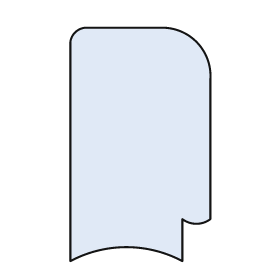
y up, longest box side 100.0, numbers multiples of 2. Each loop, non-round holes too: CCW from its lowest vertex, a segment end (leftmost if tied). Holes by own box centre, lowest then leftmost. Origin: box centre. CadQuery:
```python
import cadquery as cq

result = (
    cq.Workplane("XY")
    .moveTo(-30.0, -50.0)
    .threePointArc((-6.0, -44.0), (18.0, -50.0))
    .lineTo(18.0, -32.0)
    .threePointArc((24.0, -34.0), (30.0, -32.0))
    .lineTo(30.0, 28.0)
    .threePointArc((24.0, 44.0), (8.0, 50.0))
    .lineTo(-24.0, 50.0)
    .threePointArc((-28.0, 48.0), (-30.0, 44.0))
    .close()
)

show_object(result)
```